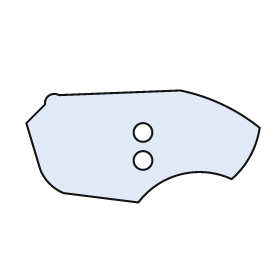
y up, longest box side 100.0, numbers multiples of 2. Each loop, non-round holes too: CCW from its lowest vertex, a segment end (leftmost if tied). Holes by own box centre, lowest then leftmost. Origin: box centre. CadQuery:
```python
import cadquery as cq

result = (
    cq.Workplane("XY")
    .moveTo(-2.0, -24.0)
    .threePointArc((16.0, -12.0), (38.0, -14.0))
    .threePointArc((46.0, -4.0), (50.0, 8.0))
    .threePointArc((34.0, 18.0), (16.0, 24.0))
    .lineTo(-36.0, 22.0)
    .threePointArc((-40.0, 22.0), (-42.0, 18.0))
    .lineTo(-50.0, 10.0)
    .lineTo(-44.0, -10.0)
    .threePointArc((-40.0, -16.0), (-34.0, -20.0))
    .close()
    .moveTo(0.0, -6.0)
    .circle(4.0)
    .moveTo(0.0, 6.0)
    .circle(4.0)
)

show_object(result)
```